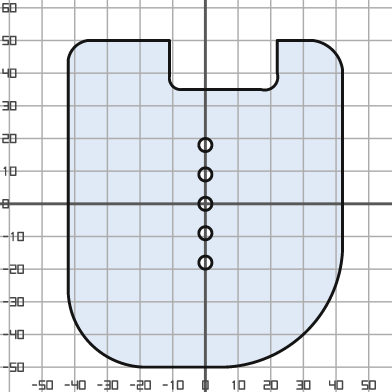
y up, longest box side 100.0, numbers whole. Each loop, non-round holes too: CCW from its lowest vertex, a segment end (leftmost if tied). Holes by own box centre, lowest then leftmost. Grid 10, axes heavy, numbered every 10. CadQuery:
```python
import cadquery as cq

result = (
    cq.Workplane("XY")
    .moveTo(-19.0, -50.0)
    .lineTo(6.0, -50.0)
    .threePointArc((31.0, -39.0), (42.0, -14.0))
    .lineTo(42.0, 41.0)
    .threePointArc((39.0, 47.0), (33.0, 50.0))
    .lineTo(22.0, 50.0)
    .lineTo(22.0, 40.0)
    .threePointArc((21.0, 36.0), (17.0, 35.0))
    .lineTo(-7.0, 35.0)
    .threePointArc((-10.0, 36.0), (-11.0, 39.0))
    .lineTo(-11.0, 50.0)
    .lineTo(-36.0, 50.0)
    .threePointArc((-40.0, 48.0), (-42.0, 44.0))
    .lineTo(-42.0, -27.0)
    .threePointArc((-35.0, -43.0), (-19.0, -50.0))
    .close()
    .moveTo(0.0, -18.0)
    .circle(2.0)
    .moveTo(0.0, -9.0)
    .circle(2.0)
    .moveTo(0.0, 0.0)
    .circle(2.0)
    .moveTo(0.0, 9.0)
    .circle(2.0)
    .moveTo(0.0, 18.0)
    .circle(2.0)
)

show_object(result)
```